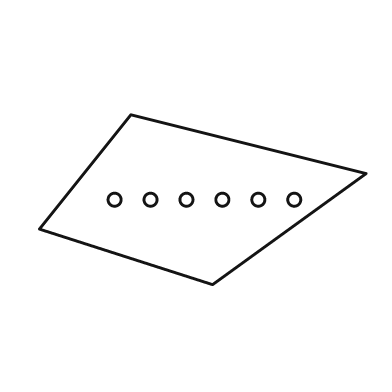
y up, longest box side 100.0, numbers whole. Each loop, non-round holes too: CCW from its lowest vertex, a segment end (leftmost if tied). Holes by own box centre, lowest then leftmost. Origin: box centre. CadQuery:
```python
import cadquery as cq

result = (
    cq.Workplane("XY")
    .moveTo(3.0, -26.0)
    .lineTo(50.0, 8.0)
    .lineTo(-22.0, 26.0)
    .lineTo(-50.0, -9.0)
    .close()
    .moveTo(-27.0, 0.0)
    .circle(2.0)
    .moveTo(-16.0, 0.0)
    .circle(2.0)
    .moveTo(-5.0, 0.0)
    .circle(2.0)
    .moveTo(6.0, 0.0)
    .circle(2.0)
    .moveTo(17.0, 0.0)
    .circle(2.0)
    .moveTo(28.0, 0.0)
    .circle(2.0)
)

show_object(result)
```